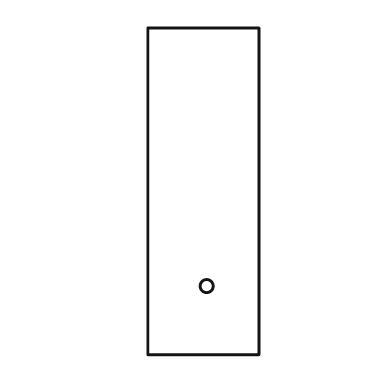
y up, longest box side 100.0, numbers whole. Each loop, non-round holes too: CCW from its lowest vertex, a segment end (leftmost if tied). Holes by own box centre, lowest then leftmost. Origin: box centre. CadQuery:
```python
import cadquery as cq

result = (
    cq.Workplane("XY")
    .moveTo(-17.0, -50.0)
    .lineTo(17.0, -50.0)
    .lineTo(17.0, 50.0)
    .lineTo(-17.0, 50.0)
    .close()
    .moveTo(1.0, -29.0)
    .circle(2.0)
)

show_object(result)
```